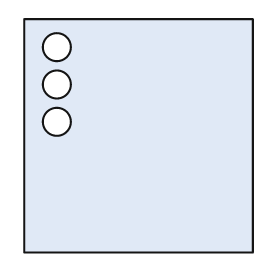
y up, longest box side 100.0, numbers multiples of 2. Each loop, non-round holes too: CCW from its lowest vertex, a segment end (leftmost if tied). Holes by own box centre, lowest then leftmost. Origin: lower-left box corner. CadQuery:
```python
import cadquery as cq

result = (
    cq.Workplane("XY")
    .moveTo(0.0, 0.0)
    .lineTo(98.0, 0.0)
    .lineTo(98.0, 100.0)
    .lineTo(0.0, 100.0)
    .close()
    .moveTo(14.0, 56.0)
    .circle(6.0)
    .moveTo(14.0, 72.0)
    .circle(6.0)
    .moveTo(14.0, 88.0)
    .circle(6.0)
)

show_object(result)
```